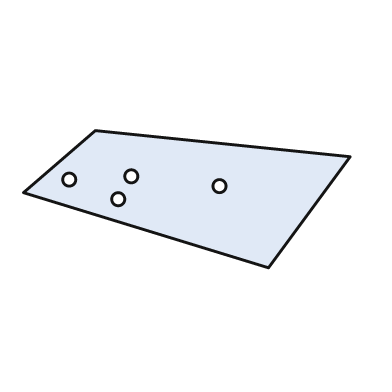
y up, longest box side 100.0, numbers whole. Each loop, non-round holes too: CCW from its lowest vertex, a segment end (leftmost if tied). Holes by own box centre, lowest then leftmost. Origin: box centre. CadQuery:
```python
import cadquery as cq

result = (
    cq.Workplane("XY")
    .moveTo(25.0, -21.0)
    .lineTo(50.0, 13.0)
    .lineTo(-28.0, 21.0)
    .lineTo(-50.0, 2.0)
    .close()
    .moveTo(-21.0, 0.0)
    .circle(2.0)
    .moveTo(10.0, 4.0)
    .circle(2.0)
    .moveTo(-36.0, 6.0)
    .circle(2.0)
    .moveTo(-17.0, 7.0)
    .circle(2.0)
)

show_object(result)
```